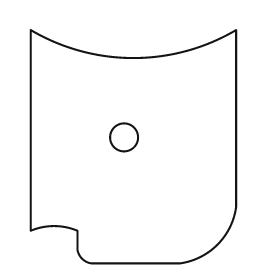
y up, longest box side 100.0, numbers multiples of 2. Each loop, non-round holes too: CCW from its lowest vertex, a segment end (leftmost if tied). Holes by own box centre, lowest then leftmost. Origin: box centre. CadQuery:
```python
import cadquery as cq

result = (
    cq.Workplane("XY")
    .moveTo(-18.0, -50.0)
    .lineTo(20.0, -50.0)
    .threePointArc((36.0, -42.0), (44.0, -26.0))
    .lineTo(44.0, 50.0)
    .threePointArc((0.0, 38.0), (-44.0, 50.0))
    .lineTo(-44.0, -36.0)
    .threePointArc((-34.0, -34.0), (-24.0, -36.0))
    .lineTo(-24.0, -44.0)
    .threePointArc((-22.0, -48.0), (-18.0, -50.0))
    .close()
    .moveTo(-4.0, 4.0)
    .circle(6.0)
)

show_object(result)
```